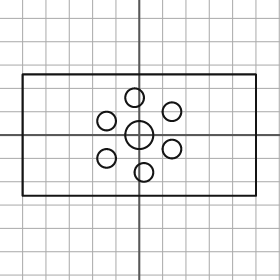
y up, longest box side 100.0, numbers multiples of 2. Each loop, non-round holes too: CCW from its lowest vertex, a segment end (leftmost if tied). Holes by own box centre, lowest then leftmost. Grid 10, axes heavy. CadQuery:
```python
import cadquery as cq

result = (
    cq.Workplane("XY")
    .moveTo(-50.0, -26.0)
    .lineTo(50.0, -26.0)
    .lineTo(50.0, 26.0)
    .lineTo(-50.0, 26.0)
    .close()
    .moveTo(2.0, -16.0)
    .circle(4.0)
    .moveTo(-14.0, -10.0)
    .circle(4.0)
    .moveTo(14.0, -6.0)
    .circle(4.0)
    .moveTo(0.0, 0.0)
    .circle(6.0)
    .moveTo(-14.0, 6.0)
    .circle(4.0)
    .moveTo(14.0, 10.0)
    .circle(4.0)
    .moveTo(-2.0, 16.0)
    .circle(4.0)
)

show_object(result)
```